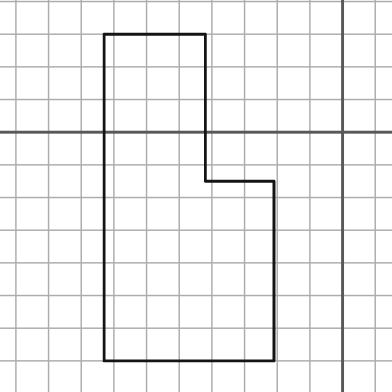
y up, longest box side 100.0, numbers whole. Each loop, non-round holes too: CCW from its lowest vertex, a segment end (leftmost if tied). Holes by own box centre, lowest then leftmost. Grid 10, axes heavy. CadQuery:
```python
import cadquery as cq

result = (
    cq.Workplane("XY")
    .moveTo(-73.0, -70.0)
    .lineTo(-21.0, -70.0)
    .lineTo(-21.0, -15.0)
    .lineTo(-42.0, -15.0)
    .lineTo(-42.0, 30.0)
    .lineTo(-73.0, 30.0)
    .close()
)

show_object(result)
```